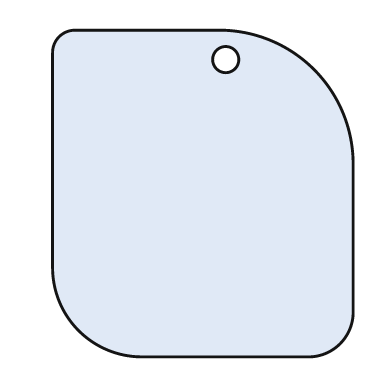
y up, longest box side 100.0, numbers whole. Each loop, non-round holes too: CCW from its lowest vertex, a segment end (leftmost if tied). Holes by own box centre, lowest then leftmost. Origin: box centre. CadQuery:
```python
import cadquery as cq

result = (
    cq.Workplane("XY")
    .moveTo(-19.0, -50.0)
    .lineTo(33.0, -50.0)
    .threePointArc((42.0, -46.0), (46.0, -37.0))
    .lineTo(46.0, 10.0)
    .threePointArc((34.0, 38.0), (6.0, 50.0))
    .lineTo(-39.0, 50.0)
    .threePointArc((-44.0, 48.0), (-46.0, 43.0))
    .lineTo(-46.0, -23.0)
    .threePointArc((-38.0, -42.0), (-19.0, -50.0))
    .close()
    .moveTo(7.0, 41.0)
    .circle(4.0)
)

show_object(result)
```